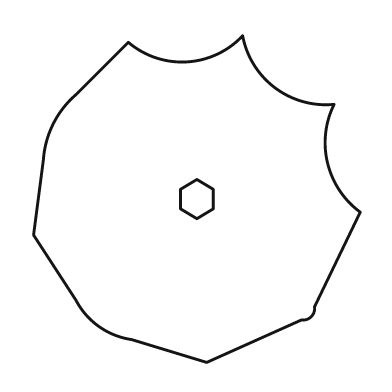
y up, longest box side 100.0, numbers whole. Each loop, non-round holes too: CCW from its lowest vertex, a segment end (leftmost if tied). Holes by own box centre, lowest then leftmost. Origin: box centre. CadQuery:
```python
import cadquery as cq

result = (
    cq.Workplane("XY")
    .moveTo(3.0, -50.0)
    .lineTo(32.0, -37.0)
    .threePointArc((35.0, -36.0), (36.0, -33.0))
    .lineTo(50.0, -4.0)
    .threePointArc((40.0, 11.0), (42.0, 29.0))
    .threePointArc((24.0, 34.0), (14.0, 50.0))
    .threePointArc((-3.0, 42.0), (-21.0, 48.0))
    .lineTo(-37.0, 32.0)
    .threePointArc((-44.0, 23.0), (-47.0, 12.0))
    .lineTo(-50.0, -11.0)
    .lineTo(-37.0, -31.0)
    .threePointArc((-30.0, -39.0), (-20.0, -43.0))
    .close()
    .moveTo(0.0, -6.0)
    .lineTo(5.0, -3.0)
    .lineTo(5.0, 3.0)
    .lineTo(0.0, 6.0)
    .lineTo(-5.0, 3.0)
    .lineTo(-5.0, -3.0)
    .close()
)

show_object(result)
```